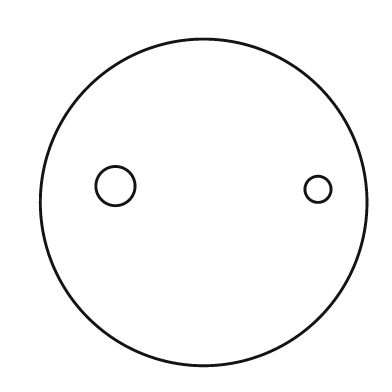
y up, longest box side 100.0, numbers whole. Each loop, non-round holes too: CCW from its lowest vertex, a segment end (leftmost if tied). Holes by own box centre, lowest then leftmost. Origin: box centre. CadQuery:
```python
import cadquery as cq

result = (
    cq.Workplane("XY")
    .moveTo(0.0, 0.0)
    .circle(50.0)
    .moveTo(35.0, 4.0)
    .circle(4.0)
    .moveTo(-27.0, 5.0)
    .circle(6.0)
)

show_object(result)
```